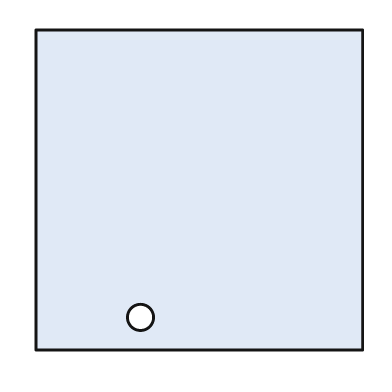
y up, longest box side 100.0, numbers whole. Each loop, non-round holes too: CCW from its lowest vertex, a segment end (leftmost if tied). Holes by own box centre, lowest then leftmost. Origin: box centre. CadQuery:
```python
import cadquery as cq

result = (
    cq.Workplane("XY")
    .moveTo(-50.0, -49.0)
    .lineTo(50.0, -49.0)
    .lineTo(50.0, 49.0)
    .lineTo(-50.0, 49.0)
    .close()
    .moveTo(-18.0, -39.0)
    .circle(4.0)
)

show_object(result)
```